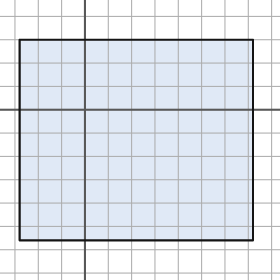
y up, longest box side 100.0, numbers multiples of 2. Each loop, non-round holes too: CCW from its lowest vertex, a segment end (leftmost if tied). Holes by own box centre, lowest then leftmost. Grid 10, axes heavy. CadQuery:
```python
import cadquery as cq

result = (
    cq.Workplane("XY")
    .moveTo(-28.0, -56.0)
    .lineTo(72.0, -56.0)
    .lineTo(72.0, 30.0)
    .lineTo(-28.0, 30.0)
    .close()
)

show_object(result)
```